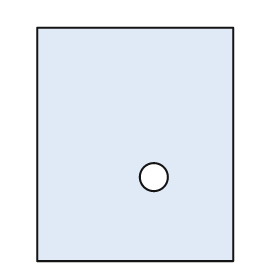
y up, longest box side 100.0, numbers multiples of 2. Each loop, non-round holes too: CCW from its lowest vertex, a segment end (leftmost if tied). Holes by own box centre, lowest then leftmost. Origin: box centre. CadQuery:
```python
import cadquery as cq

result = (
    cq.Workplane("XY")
    .moveTo(-42.0, -50.0)
    .lineTo(42.0, -50.0)
    .lineTo(42.0, 50.0)
    .lineTo(-42.0, 50.0)
    .close()
    .moveTo(8.0, -14.0)
    .circle(6.0)
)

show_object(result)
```